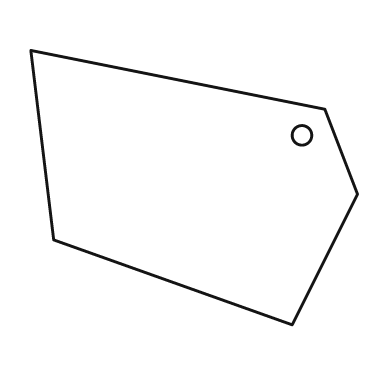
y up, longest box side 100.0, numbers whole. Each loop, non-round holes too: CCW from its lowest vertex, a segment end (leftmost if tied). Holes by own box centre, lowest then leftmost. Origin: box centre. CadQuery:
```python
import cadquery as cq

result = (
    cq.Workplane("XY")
    .moveTo(30.0, -42.0)
    .lineTo(50.0, -2.0)
    .lineTo(40.0, 24.0)
    .lineTo(-50.0, 42.0)
    .lineTo(-43.0, -16.0)
    .close()
    .moveTo(33.0, 16.0)
    .circle(3.0)
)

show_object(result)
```